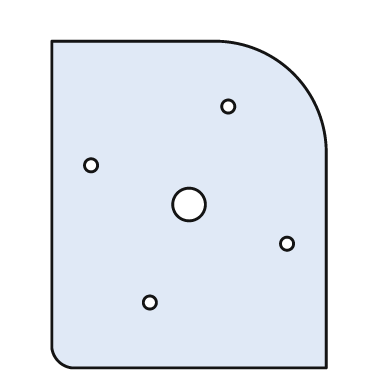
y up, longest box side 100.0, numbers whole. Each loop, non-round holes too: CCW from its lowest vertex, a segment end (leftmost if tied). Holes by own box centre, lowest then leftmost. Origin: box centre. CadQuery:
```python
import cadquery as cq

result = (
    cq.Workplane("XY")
    .moveTo(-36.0, -50.0)
    .lineTo(42.0, -50.0)
    .lineTo(42.0, 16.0)
    .threePointArc((32.0, 40.0), (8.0, 50.0))
    .lineTo(-42.0, 50.0)
    .lineTo(-42.0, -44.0)
    .threePointArc((-40.0, -48.0), (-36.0, -50.0))
    .close()
    .moveTo(-12.0, -30.0)
    .circle(2.0)
    .moveTo(30.0, -12.0)
    .circle(2.0)
    .moveTo(0.0, 0.0)
    .circle(5.0)
    .moveTo(-30.0, 12.0)
    .circle(2.0)
    .moveTo(12.0, 30.0)
    .circle(2.0)
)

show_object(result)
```